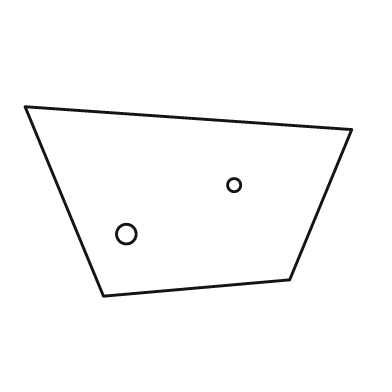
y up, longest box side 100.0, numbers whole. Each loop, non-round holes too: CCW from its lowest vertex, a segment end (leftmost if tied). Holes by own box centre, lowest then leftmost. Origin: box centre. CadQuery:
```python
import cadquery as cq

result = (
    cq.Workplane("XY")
    .moveTo(-26.0, -29.0)
    .lineTo(31.0, -24.0)
    .lineTo(50.0, 22.0)
    .lineTo(-50.0, 29.0)
    .close()
    .moveTo(-19.0, -10.0)
    .circle(3.0)
    .moveTo(14.0, 5.0)
    .circle(2.0)
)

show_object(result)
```